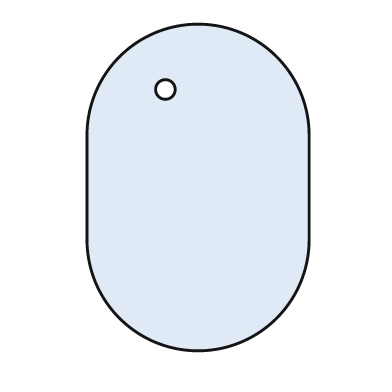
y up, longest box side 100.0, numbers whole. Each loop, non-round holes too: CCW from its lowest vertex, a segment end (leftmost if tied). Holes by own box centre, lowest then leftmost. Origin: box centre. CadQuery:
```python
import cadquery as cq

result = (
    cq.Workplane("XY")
    .moveTo(-34.0, -16.0)
    .threePointArc((0.0, -50.0), (34.0, -16.0))
    .lineTo(34.0, 16.0)
    .threePointArc((0.0, 50.0), (-34.0, 16.0))
    .close()
    .moveTo(-10.0, 30.0)
    .circle(3.0)
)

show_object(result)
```